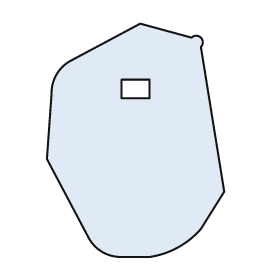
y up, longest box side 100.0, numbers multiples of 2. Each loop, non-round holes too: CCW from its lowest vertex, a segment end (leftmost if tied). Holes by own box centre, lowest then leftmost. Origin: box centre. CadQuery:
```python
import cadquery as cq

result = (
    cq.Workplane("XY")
    .moveTo(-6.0, -50.0)
    .lineTo(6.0, -50.0)
    .threePointArc((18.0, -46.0), (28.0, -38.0))
    .lineTo(38.0, -22.0)
    .lineTo(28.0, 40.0)
    .threePointArc((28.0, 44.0), (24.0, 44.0))
    .lineTo(2.0, 50.0)
    .lineTo(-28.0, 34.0)
    .threePointArc((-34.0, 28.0), (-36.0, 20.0))
    .lineTo(-38.0, -8.0)
    .lineTo(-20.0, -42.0)
    .threePointArc((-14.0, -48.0), (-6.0, -50.0))
    .close()
    .moveTo(-6.0, 18.0)
    .lineTo(6.0, 18.0)
    .lineTo(6.0, 26.0)
    .lineTo(-6.0, 26.0)
    .close()
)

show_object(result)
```